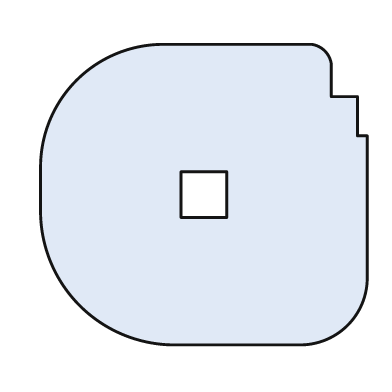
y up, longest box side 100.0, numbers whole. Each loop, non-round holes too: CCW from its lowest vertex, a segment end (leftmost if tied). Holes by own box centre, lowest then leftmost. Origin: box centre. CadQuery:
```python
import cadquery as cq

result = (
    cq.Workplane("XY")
    .moveTo(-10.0, -46.0)
    .lineTo(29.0, -46.0)
    .threePointArc((44.0, -40.0), (50.0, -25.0))
    .lineTo(50.0, 18.0)
    .lineTo(47.0, 18.0)
    .lineTo(47.0, 30.0)
    .lineTo(39.0, 30.0)
    .lineTo(39.0, 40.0)
    .threePointArc((37.0, 44.0), (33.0, 46.0))
    .lineTo(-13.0, 46.0)
    .threePointArc((-39.0, 35.0), (-50.0, 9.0))
    .lineTo(-50.0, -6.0)
    .threePointArc((-38.0, -34.0), (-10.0, -46.0))
    .close()
    .moveTo(-7.0, -7.0)
    .lineTo(7.0, -7.0)
    .lineTo(7.0, 7.0)
    .lineTo(-7.0, 7.0)
    .close()
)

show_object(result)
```